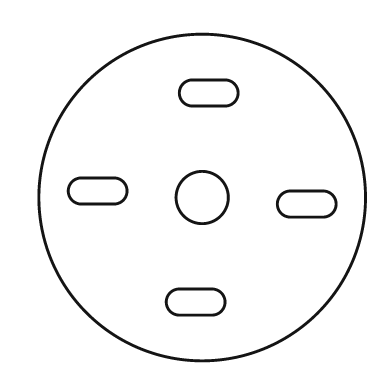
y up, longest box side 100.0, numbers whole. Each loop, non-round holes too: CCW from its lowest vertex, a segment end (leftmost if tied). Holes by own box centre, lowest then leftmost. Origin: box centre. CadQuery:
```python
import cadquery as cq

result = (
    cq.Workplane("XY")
    .moveTo(0.0, 0.0)
    .circle(50.0)
    .moveTo(-7.0, -36.0)
    .lineTo(3.0, -36.0)
    .threePointArc((7.0, -32.0), (3.0, -28.0))
    .lineTo(-7.0, -28.0)
    .threePointArc((-11.0, -32.0), (-7.0, -36.0))
    .close()
    .moveTo(27.0, -6.0)
    .lineTo(37.0, -6.0)
    .threePointArc((41.0, -2.0), (37.0, 2.0))
    .lineTo(27.0, 2.0)
    .threePointArc((23.0, -2.0), (27.0, -6.0))
    .close()
    .moveTo(0.0, 0.0)
    .circle(8.0)
    .moveTo(-37.0, -2.0)
    .lineTo(-27.0, -2.0)
    .threePointArc((-23.0, 2.0), (-27.0, 6.0))
    .lineTo(-37.0, 6.0)
    .threePointArc((-41.0, 2.0), (-37.0, -2.0))
    .close()
    .moveTo(-3.0, 28.0)
    .lineTo(7.0, 28.0)
    .threePointArc((11.0, 32.0), (7.0, 36.0))
    .lineTo(-3.0, 36.0)
    .threePointArc((-7.0, 32.0), (-3.0, 28.0))
    .close()
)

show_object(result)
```